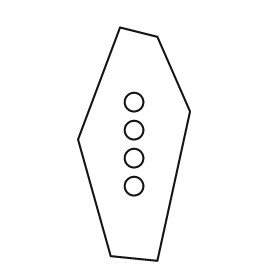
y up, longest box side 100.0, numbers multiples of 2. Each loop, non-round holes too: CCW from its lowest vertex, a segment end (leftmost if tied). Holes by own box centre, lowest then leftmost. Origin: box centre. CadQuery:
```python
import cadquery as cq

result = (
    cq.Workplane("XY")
    .moveTo(10.0, -50.0)
    .lineTo(24.0, 14.0)
    .lineTo(10.0, 46.0)
    .lineTo(-6.0, 50.0)
    .lineTo(-24.0, 2.0)
    .lineTo(-10.0, -48.0)
    .close()
    .moveTo(0.0, -18.0)
    .circle(4.0)
    .moveTo(0.0, -6.0)
    .circle(4.0)
    .moveTo(0.0, 6.0)
    .circle(4.0)
    .moveTo(0.0, 18.0)
    .circle(4.0)
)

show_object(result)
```